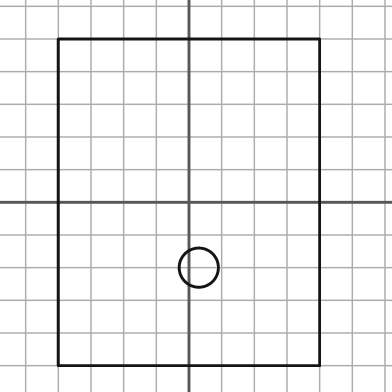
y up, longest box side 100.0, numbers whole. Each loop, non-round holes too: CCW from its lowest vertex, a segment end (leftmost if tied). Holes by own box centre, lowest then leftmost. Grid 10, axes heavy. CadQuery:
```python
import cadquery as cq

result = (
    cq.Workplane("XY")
    .moveTo(-40.0, -50.0)
    .lineTo(40.0, -50.0)
    .lineTo(40.0, 50.0)
    .lineTo(-40.0, 50.0)
    .close()
    .moveTo(3.0, -20.0)
    .circle(6.0)
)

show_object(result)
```